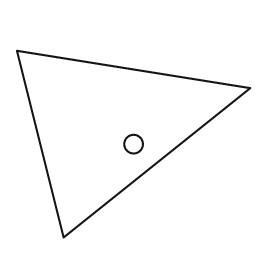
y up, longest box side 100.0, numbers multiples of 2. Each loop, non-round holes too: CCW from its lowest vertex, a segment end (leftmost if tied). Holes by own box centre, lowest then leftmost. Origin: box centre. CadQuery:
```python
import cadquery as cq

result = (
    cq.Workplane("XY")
    .moveTo(-30.0, -40.0)
    .lineTo(50.0, 24.0)
    .lineTo(-50.0, 40.0)
    .close()
    .moveTo(0.0, 0.0)
    .circle(4.0)
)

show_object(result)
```